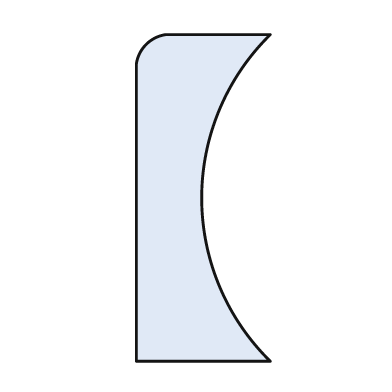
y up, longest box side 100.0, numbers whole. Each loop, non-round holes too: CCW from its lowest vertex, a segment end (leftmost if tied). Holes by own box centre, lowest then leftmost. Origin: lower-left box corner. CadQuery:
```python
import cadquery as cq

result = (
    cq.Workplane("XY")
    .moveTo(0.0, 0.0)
    .lineTo(41.0, 0.0)
    .threePointArc((20.0, 50.0), (41.0, 100.0))
    .lineTo(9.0, 100.0)
    .threePointArc((3.0, 97.0), (0.0, 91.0))
    .close()
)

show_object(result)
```